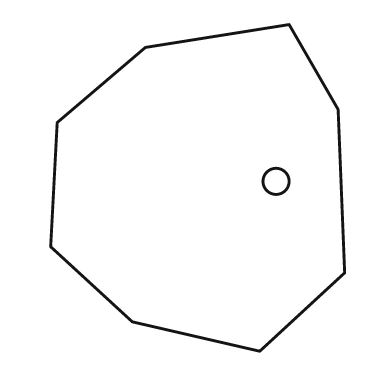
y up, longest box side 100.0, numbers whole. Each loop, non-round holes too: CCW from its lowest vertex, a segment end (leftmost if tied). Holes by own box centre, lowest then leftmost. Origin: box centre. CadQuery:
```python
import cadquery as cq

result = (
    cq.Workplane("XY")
    .moveTo(19.0, -50.0)
    .lineTo(45.0, -26.0)
    .lineTo(43.0, 24.0)
    .lineTo(28.0, 50.0)
    .lineTo(-16.0, 43.0)
    .lineTo(-43.0, 20.0)
    .lineTo(-45.0, -18.0)
    .lineTo(-20.0, -41.0)
    .close()
    .moveTo(24.0, 2.0)
    .circle(4.0)
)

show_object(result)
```